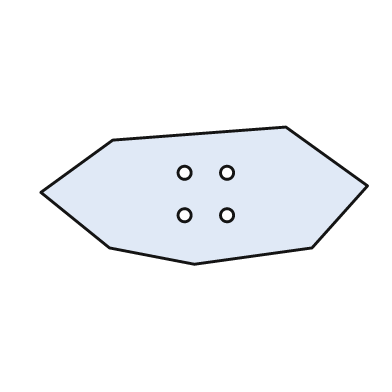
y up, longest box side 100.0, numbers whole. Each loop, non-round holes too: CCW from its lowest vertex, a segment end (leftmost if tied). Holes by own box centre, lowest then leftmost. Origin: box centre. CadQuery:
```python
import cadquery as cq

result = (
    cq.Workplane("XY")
    .moveTo(-3.0, -21.0)
    .lineTo(33.0, -16.0)
    .lineTo(50.0, 3.0)
    .lineTo(25.0, 21.0)
    .lineTo(-28.0, 17.0)
    .lineTo(-50.0, 1.0)
    .lineTo(-29.0, -16.0)
    .close()
    .moveTo(-6.0, -6.0)
    .circle(2.0)
    .moveTo(7.0, -6.0)
    .circle(2.0)
    .moveTo(-6.0, 7.0)
    .circle(2.0)
    .moveTo(7.0, 7.0)
    .circle(2.0)
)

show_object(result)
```